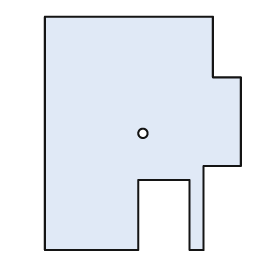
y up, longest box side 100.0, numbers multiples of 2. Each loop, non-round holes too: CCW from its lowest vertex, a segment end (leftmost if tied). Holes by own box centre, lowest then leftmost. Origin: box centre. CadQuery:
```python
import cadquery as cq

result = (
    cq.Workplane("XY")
    .moveTo(-42.0, -50.0)
    .lineTo(-2.0, -50.0)
    .lineTo(-2.0, -20.0)
    .lineTo(20.0, -20.0)
    .lineTo(20.0, -50.0)
    .lineTo(26.0, -50.0)
    .lineTo(26.0, -14.0)
    .lineTo(42.0, -14.0)
    .lineTo(42.0, 24.0)
    .lineTo(30.0, 24.0)
    .lineTo(30.0, 50.0)
    .lineTo(-42.0, 50.0)
    .close()
    .moveTo(0.0, 0.0)
    .circle(2.0)
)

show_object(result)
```